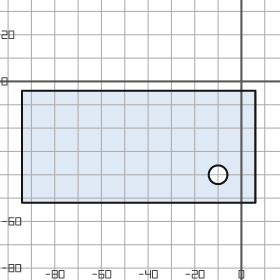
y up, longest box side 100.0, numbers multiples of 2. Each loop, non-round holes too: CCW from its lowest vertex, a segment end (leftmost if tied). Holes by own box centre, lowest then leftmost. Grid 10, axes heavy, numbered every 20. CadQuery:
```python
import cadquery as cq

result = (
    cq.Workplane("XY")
    .moveTo(-94.0, -52.0)
    .lineTo(6.0, -52.0)
    .lineTo(6.0, -4.0)
    .lineTo(-94.0, -4.0)
    .close()
    .moveTo(-10.0, -40.0)
    .circle(4.0)
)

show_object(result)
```